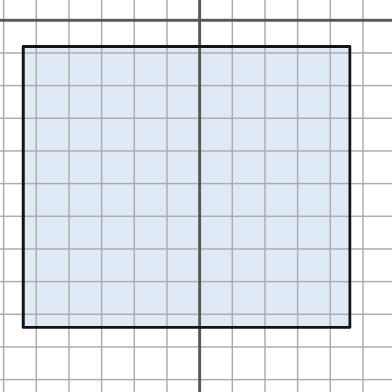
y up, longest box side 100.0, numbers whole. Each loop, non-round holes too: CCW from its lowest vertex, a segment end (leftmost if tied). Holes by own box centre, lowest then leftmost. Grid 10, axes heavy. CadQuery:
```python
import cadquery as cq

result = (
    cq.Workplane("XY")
    .moveTo(-54.0, -94.0)
    .lineTo(46.0, -94.0)
    .lineTo(46.0, -8.0)
    .lineTo(-54.0, -8.0)
    .close()
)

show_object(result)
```